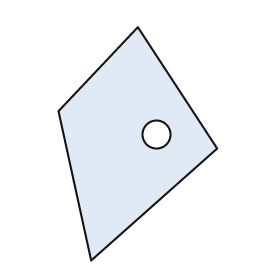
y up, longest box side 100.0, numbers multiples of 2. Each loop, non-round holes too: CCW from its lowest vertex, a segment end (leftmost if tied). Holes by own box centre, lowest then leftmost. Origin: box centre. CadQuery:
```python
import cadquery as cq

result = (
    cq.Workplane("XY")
    .moveTo(-20.0, -50.0)
    .lineTo(34.0, -2.0)
    .lineTo(0.0, 50.0)
    .lineTo(-34.0, 14.0)
    .close()
    .moveTo(8.0, 4.0)
    .circle(6.0)
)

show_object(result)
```